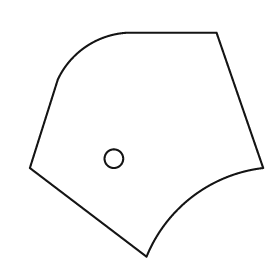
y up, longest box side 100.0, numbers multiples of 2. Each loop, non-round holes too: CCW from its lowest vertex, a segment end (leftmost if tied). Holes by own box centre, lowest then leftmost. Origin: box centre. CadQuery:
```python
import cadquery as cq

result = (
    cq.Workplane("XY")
    .moveTo(0.0, -48.0)
    .threePointArc((20.0, -22.0), (50.0, -10.0))
    .lineTo(30.0, 48.0)
    .lineTo(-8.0, 48.0)
    .threePointArc((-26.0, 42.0), (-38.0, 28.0))
    .lineTo(-50.0, -10.0)
    .close()
    .moveTo(-14.0, -6.0)
    .circle(4.0)
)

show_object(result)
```